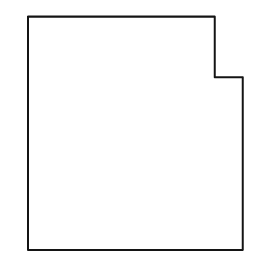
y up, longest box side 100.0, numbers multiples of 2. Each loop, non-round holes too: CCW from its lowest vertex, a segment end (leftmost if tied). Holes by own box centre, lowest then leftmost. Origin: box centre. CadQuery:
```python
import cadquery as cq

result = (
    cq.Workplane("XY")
    .moveTo(-46.0, -50.0)
    .lineTo(46.0, -50.0)
    .lineTo(46.0, 24.0)
    .lineTo(34.0, 24.0)
    .lineTo(34.0, 50.0)
    .lineTo(-46.0, 50.0)
    .close()
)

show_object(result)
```